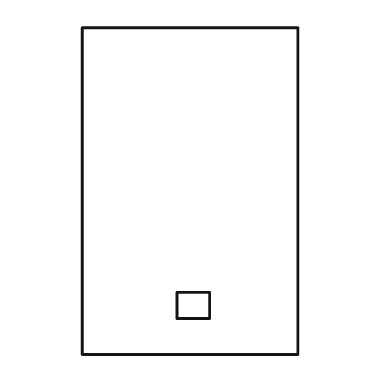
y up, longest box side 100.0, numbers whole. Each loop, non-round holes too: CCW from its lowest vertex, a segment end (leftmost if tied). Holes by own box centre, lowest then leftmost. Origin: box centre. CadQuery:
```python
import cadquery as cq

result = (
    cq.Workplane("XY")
    .moveTo(-33.0, -50.0)
    .lineTo(33.0, -50.0)
    .lineTo(33.0, 50.0)
    .lineTo(-33.0, 50.0)
    .close()
    .moveTo(-4.0, -39.0)
    .lineTo(6.0, -39.0)
    .lineTo(6.0, -31.0)
    .lineTo(-4.0, -31.0)
    .close()
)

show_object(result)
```